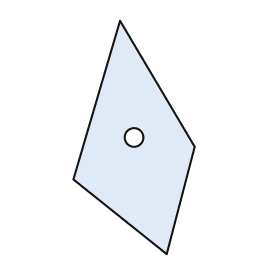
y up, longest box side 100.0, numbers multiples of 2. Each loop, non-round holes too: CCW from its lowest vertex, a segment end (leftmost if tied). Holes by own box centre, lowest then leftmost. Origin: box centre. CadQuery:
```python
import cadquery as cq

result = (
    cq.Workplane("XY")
    .moveTo(14.0, -50.0)
    .lineTo(26.0, -4.0)
    .lineTo(-6.0, 50.0)
    .lineTo(-26.0, -18.0)
    .close()
    .moveTo(0.0, 0.0)
    .circle(4.0)
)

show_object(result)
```